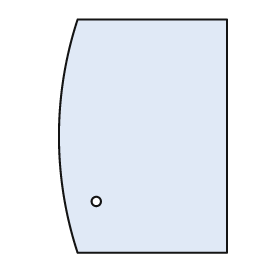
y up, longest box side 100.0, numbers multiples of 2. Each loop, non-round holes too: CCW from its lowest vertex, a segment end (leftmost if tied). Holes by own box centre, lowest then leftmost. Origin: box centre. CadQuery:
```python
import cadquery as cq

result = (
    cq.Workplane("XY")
    .moveTo(-28.0, -50.0)
    .lineTo(36.0, -50.0)
    .lineTo(36.0, 50.0)
    .lineTo(-28.0, 50.0)
    .threePointArc((-36.0, 0.0), (-28.0, -50.0))
    .close()
    .moveTo(-20.0, -28.0)
    .circle(2.0)
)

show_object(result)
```